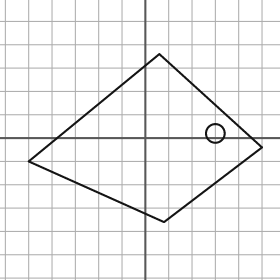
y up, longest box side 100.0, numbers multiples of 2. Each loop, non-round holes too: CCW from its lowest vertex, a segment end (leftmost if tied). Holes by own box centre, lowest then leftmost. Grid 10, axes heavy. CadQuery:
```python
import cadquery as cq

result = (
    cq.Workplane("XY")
    .moveTo(8.0, -36.0)
    .lineTo(50.0, -4.0)
    .lineTo(6.0, 36.0)
    .lineTo(-50.0, -10.0)
    .close()
    .moveTo(30.0, 2.0)
    .circle(4.0)
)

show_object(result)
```